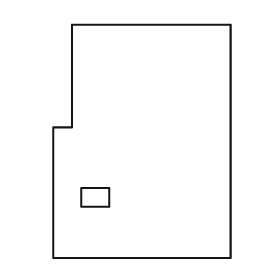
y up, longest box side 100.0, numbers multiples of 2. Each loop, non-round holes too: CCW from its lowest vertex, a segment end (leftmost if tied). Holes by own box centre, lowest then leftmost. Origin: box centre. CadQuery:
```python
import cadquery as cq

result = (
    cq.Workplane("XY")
    .moveTo(-38.0, -50.0)
    .lineTo(38.0, -50.0)
    .lineTo(38.0, 50.0)
    .lineTo(-30.0, 50.0)
    .lineTo(-30.0, 6.0)
    .lineTo(-38.0, 6.0)
    .close()
    .moveTo(-26.0, -28.0)
    .lineTo(-14.0, -28.0)
    .lineTo(-14.0, -20.0)
    .lineTo(-26.0, -20.0)
    .close()
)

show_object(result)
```